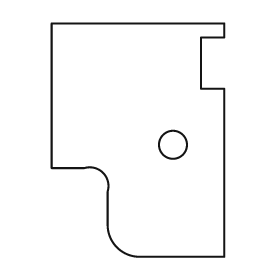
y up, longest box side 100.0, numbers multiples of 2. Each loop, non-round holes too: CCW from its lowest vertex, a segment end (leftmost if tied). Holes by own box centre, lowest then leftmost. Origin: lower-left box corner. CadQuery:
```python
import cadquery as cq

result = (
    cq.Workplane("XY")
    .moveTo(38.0, 0.0)
    .lineTo(74.0, 0.0)
    .lineTo(74.0, 72.0)
    .lineTo(64.0, 72.0)
    .lineTo(64.0, 94.0)
    .lineTo(74.0, 94.0)
    .lineTo(74.0, 100.0)
    .lineTo(0.0, 100.0)
    .lineTo(0.0, 38.0)
    .lineTo(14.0, 38.0)
    .threePointArc((22.0, 36.0), (24.0, 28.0))
    .lineTo(24.0, 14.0)
    .threePointArc((28.0, 4.0), (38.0, 0.0))
    .close()
    .moveTo(52.0, 48.0)
    .circle(6.0)
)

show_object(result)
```